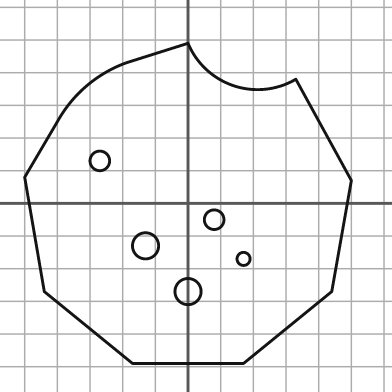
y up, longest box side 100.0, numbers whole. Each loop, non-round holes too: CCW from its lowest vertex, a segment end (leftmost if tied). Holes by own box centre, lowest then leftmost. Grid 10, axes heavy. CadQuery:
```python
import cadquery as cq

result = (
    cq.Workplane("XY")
    .moveTo(-17.0, -49.0)
    .lineTo(17.0, -49.0)
    .lineTo(44.0, -27.0)
    .lineTo(50.0, 7.0)
    .lineTo(33.0, 38.0)
    .threePointArc((14.0, 36.0), (0.0, 49.0))
    .lineTo(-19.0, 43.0)
    .threePointArc((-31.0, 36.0), (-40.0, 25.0))
    .lineTo(-50.0, 8.0)
    .lineTo(-44.0, -27.0)
    .close()
    .moveTo(0.0, -27.0)
    .circle(4.0)
    .moveTo(17.0, -17.0)
    .circle(2.0)
    .moveTo(-13.0, -13.0)
    .circle(4.0)
    .moveTo(8.0, -5.0)
    .circle(3.0)
    .moveTo(-27.0, 13.0)
    .circle(3.0)
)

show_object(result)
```